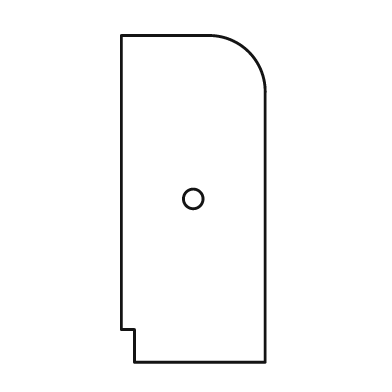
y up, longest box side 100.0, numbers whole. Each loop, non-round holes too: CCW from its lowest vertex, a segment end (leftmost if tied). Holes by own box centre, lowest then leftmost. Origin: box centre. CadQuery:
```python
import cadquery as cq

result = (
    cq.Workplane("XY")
    .moveTo(-18.0, -50.0)
    .lineTo(22.0, -50.0)
    .lineTo(22.0, 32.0)
    .threePointArc((17.0, 45.0), (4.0, 50.0))
    .lineTo(-22.0, 50.0)
    .lineTo(-22.0, -40.0)
    .lineTo(-18.0, -40.0)
    .close()
    .moveTo(0.0, 0.0)
    .circle(3.0)
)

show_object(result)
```